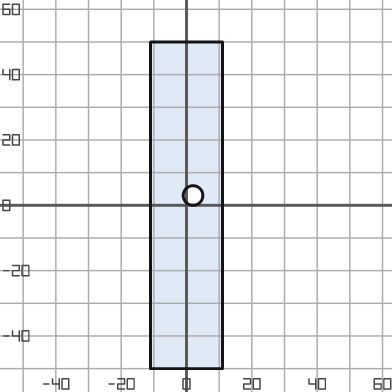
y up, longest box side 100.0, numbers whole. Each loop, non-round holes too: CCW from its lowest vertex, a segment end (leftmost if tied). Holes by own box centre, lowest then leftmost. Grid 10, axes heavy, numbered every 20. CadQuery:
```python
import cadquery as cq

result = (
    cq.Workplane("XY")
    .moveTo(-11.0, -50.0)
    .lineTo(11.0, -50.0)
    .lineTo(11.0, 50.0)
    .lineTo(-11.0, 50.0)
    .close()
    .moveTo(2.0, 3.0)
    .circle(3.0)
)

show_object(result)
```